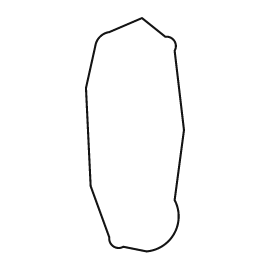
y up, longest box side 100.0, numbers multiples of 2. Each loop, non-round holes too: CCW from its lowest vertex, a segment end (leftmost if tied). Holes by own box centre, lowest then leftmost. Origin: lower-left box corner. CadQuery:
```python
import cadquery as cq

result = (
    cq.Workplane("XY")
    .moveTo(26.0, 0.0)
    .threePointArc((38.0, 8.0), (38.0, 22.0))
    .lineTo(42.0, 52.0)
    .lineTo(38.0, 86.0)
    .threePointArc((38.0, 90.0), (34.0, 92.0))
    .lineTo(24.0, 100.0)
    .lineTo(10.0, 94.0)
    .threePointArc((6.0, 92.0), (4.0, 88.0))
    .lineTo(0.0, 70.0)
    .lineTo(2.0, 28.0)
    .lineTo(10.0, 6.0)
    .threePointArc((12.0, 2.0), (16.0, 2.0))
    .close()
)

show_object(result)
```